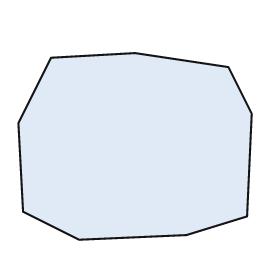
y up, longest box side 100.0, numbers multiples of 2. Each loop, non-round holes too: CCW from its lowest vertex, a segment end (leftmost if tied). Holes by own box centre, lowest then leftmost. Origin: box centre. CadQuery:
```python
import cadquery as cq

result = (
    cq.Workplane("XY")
    .moveTo(-24.0, -40.0)
    .lineTo(22.0, -38.0)
    .lineTo(48.0, -30.0)
    .lineTo(50.0, 14.0)
    .lineTo(40.0, 34.0)
    .lineTo(0.0, 40.0)
    .lineTo(-36.0, 38.0)
    .lineTo(-50.0, 10.0)
    .lineTo(-48.0, -28.0)
    .close()
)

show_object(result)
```